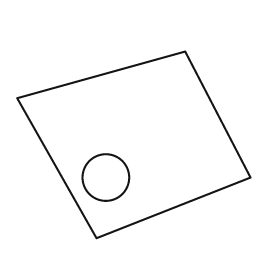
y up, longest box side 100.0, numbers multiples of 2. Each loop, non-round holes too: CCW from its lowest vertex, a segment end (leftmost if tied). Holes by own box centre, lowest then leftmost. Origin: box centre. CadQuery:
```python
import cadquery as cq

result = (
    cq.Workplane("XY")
    .moveTo(-16.0, -40.0)
    .lineTo(50.0, -14.0)
    .lineTo(22.0, 40.0)
    .lineTo(-50.0, 20.0)
    .close()
    .moveTo(-12.0, -14.0)
    .circle(10.0)
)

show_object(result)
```